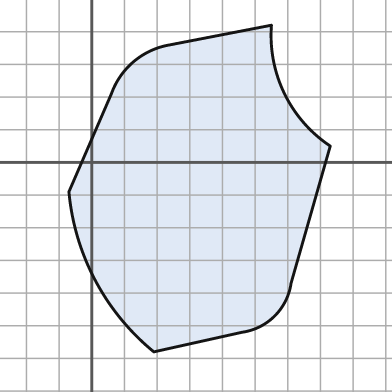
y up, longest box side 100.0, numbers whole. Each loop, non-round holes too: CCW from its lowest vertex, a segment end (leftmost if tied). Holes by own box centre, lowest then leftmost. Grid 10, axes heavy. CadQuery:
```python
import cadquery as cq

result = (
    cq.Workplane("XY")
    .moveTo(19.0, -58.0)
    .lineTo(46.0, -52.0)
    .threePointArc((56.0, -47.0), (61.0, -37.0))
    .lineTo(73.0, 5.0)
    .threePointArc((59.0, 21.0), (55.0, 42.0))
    .lineTo(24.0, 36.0)
    .threePointArc((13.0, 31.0), (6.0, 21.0))
    .lineTo(-7.0, -9.0)
    .threePointArc((1.0, -36.0), (19.0, -58.0))
    .close()
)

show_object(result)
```